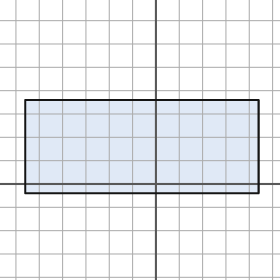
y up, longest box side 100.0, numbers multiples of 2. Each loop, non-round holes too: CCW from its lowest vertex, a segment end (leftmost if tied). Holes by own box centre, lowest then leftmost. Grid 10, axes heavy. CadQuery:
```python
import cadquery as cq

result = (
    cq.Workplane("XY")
    .moveTo(-56.0, -4.0)
    .lineTo(44.0, -4.0)
    .lineTo(44.0, 36.0)
    .lineTo(-56.0, 36.0)
    .close()
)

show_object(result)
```